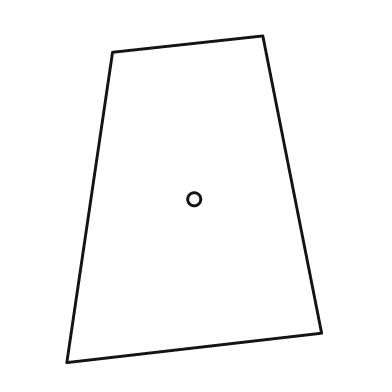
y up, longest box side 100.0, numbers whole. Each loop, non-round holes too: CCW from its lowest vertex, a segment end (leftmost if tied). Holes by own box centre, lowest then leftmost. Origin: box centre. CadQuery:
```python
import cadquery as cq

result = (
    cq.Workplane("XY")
    .moveTo(-39.0, -50.0)
    .lineTo(39.0, -41.0)
    .lineTo(21.0, 50.0)
    .lineTo(-25.0, 45.0)
    .close()
    .moveTo(0.0, 0.0)
    .circle(2.0)
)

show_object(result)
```